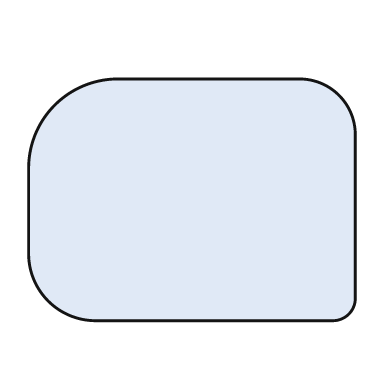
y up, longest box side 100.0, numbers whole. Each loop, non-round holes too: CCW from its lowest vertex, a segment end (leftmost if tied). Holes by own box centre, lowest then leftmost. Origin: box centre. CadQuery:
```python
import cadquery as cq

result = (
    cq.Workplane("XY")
    .moveTo(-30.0, -37.0)
    .lineTo(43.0, -37.0)
    .threePointArc((48.0, -35.0), (50.0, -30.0))
    .lineTo(50.0, 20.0)
    .threePointArc((45.0, 32.0), (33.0, 37.0))
    .lineTo(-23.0, 37.0)
    .threePointArc((-42.0, 29.0), (-50.0, 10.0))
    .lineTo(-50.0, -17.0)
    .threePointArc((-44.0, -31.0), (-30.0, -37.0))
    .close()
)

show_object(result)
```